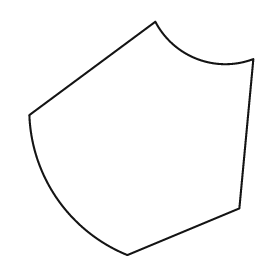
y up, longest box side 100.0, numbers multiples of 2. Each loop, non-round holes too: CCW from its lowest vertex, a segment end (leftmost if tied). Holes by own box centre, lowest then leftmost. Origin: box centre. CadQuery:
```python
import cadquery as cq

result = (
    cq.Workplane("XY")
    .moveTo(-6.0, -50.0)
    .lineTo(42.0, -30.0)
    .lineTo(48.0, 34.0)
    .threePointArc((24.0, 34.0), (6.0, 50.0))
    .lineTo(-48.0, 10.0)
    .threePointArc((-36.0, -26.0), (-6.0, -50.0))
    .close()
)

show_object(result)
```